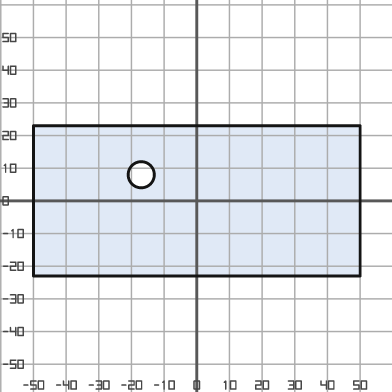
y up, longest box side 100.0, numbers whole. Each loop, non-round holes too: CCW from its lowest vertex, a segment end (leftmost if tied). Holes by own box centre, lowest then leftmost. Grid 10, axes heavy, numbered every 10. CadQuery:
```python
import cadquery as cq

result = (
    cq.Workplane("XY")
    .moveTo(-50.0, -23.0)
    .lineTo(50.0, -23.0)
    .lineTo(50.0, 23.0)
    .lineTo(-50.0, 23.0)
    .close()
    .moveTo(-17.0, 8.0)
    .circle(4.0)
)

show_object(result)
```